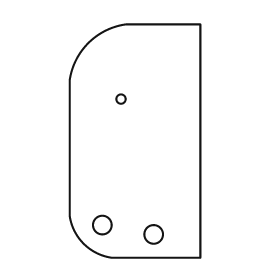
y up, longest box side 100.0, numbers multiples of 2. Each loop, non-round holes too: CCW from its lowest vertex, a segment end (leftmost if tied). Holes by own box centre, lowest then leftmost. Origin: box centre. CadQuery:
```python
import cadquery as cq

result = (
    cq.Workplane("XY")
    .moveTo(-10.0, -50.0)
    .lineTo(28.0, -50.0)
    .lineTo(28.0, 50.0)
    .lineTo(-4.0, 50.0)
    .threePointArc((-20.0, 42.0), (-28.0, 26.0))
    .lineTo(-28.0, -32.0)
    .threePointArc((-22.0, -44.0), (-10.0, -50.0))
    .close()
    .moveTo(8.0, -40.0)
    .circle(4.0)
    .moveTo(-14.0, -36.0)
    .circle(4.0)
    .moveTo(-6.0, 18.0)
    .circle(2.0)
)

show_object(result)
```